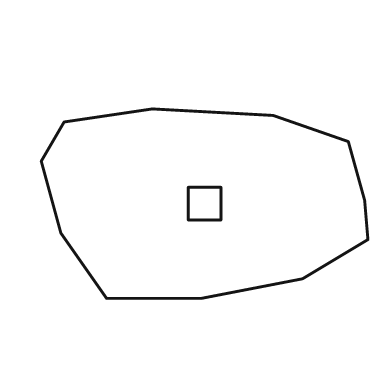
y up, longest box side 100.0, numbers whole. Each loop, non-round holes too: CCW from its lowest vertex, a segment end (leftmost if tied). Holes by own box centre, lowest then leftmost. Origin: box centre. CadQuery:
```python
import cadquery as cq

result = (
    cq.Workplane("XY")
    .moveTo(-30.0, -29.0)
    .lineTo(-1.0, -29.0)
    .lineTo(30.0, -23.0)
    .lineTo(50.0, -11.0)
    .lineTo(49.0, 1.0)
    .lineTo(44.0, 19.0)
    .lineTo(21.0, 27.0)
    .lineTo(-16.0, 29.0)
    .lineTo(-43.0, 25.0)
    .lineTo(-50.0, 13.0)
    .lineTo(-44.0, -9.0)
    .close()
    .moveTo(-5.0, -5.0)
    .lineTo(5.0, -5.0)
    .lineTo(5.0, 5.0)
    .lineTo(-5.0, 5.0)
    .close()
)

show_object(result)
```